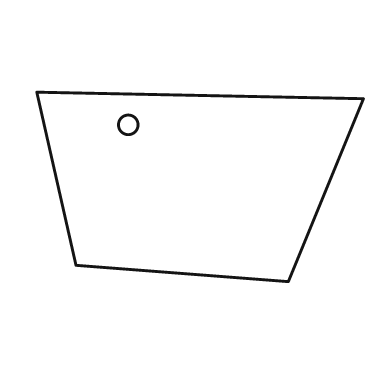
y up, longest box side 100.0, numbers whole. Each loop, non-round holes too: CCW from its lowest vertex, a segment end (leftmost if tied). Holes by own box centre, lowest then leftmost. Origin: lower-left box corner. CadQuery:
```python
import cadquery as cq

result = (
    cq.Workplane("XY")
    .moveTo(77.0, 0.0)
    .lineTo(100.0, 56.0)
    .lineTo(0.0, 58.0)
    .lineTo(12.0, 5.0)
    .close()
    .moveTo(28.0, 48.0)
    .circle(3.0)
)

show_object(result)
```